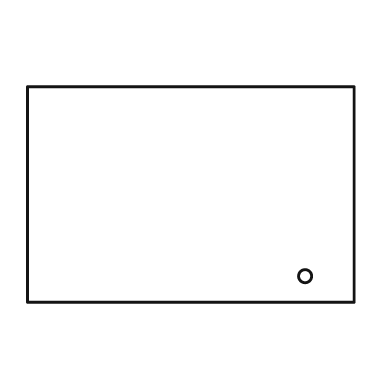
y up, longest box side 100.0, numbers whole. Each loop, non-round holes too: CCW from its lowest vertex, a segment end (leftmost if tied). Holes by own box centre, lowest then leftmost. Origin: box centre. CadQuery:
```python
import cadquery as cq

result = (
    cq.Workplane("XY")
    .moveTo(-50.0, -33.0)
    .lineTo(50.0, -33.0)
    .lineTo(50.0, 33.0)
    .lineTo(-50.0, 33.0)
    .close()
    .moveTo(35.0, -25.0)
    .circle(2.0)
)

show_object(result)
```